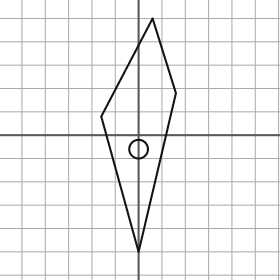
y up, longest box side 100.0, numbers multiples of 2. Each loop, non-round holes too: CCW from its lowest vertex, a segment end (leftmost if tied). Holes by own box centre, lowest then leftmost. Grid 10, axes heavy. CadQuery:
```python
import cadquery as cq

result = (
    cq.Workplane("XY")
    .moveTo(0.0, -50.0)
    .lineTo(16.0, 18.0)
    .lineTo(6.0, 50.0)
    .lineTo(-16.0, 8.0)
    .close()
    .moveTo(0.0, -6.0)
    .circle(4.0)
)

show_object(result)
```